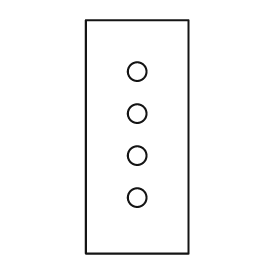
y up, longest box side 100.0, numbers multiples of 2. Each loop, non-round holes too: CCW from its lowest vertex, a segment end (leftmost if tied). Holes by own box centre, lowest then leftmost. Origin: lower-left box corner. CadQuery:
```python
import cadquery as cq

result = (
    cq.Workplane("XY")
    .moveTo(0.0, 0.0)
    .lineTo(44.0, 0.0)
    .lineTo(44.0, 100.0)
    .lineTo(0.0, 100.0)
    .close()
    .moveTo(22.0, 24.0)
    .circle(4.0)
    .moveTo(22.0, 42.0)
    .circle(4.0)
    .moveTo(22.0, 60.0)
    .circle(4.0)
    .moveTo(22.0, 78.0)
    .circle(4.0)
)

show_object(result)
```